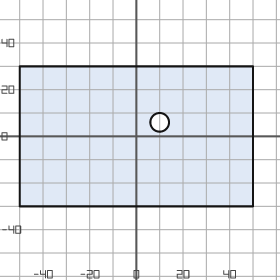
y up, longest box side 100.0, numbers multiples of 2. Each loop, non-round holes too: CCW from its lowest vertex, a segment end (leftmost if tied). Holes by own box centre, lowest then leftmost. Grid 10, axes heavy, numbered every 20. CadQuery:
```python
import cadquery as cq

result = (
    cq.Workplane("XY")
    .moveTo(-50.0, -30.0)
    .lineTo(50.0, -30.0)
    .lineTo(50.0, 30.0)
    .lineTo(-50.0, 30.0)
    .close()
    .moveTo(10.0, 6.0)
    .circle(4.0)
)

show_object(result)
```